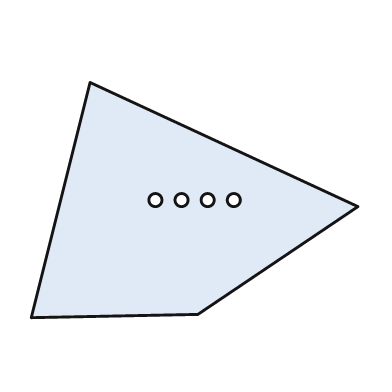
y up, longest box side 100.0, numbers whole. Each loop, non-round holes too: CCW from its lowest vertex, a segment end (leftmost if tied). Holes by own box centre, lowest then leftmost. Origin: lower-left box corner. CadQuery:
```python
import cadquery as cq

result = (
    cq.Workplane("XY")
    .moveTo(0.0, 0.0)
    .lineTo(51.0, 1.0)
    .lineTo(100.0, 34.0)
    .lineTo(18.0, 72.0)
    .close()
    .moveTo(38.0, 36.0)
    .circle(2.0)
    .moveTo(46.0, 36.0)
    .circle(2.0)
    .moveTo(54.0, 36.0)
    .circle(2.0)
    .moveTo(62.0, 36.0)
    .circle(2.0)
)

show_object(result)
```